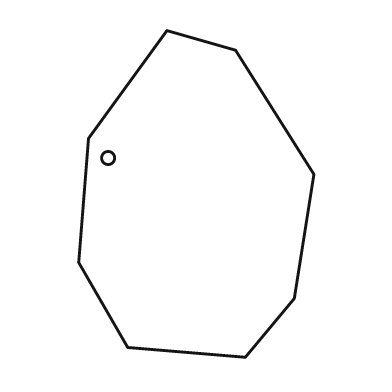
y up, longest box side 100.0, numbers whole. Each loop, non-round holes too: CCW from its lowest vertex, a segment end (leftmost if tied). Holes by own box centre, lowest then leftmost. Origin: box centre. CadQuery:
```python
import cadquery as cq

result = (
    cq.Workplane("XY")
    .moveTo(15.0, -50.0)
    .lineTo(30.0, -32.0)
    .lineTo(36.0, 6.0)
    .lineTo(12.0, 44.0)
    .lineTo(-9.0, 50.0)
    .lineTo(-33.0, 17.0)
    .lineTo(-36.0, -21.0)
    .lineTo(-21.0, -47.0)
    .close()
    .moveTo(-27.0, 11.0)
    .circle(2.0)
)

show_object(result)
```